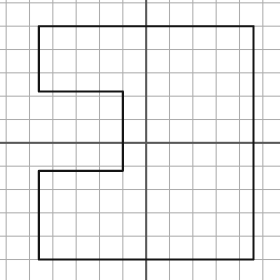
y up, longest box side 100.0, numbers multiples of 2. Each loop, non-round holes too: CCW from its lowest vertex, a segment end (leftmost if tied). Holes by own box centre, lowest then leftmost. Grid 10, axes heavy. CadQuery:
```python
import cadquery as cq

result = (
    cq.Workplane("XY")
    .moveTo(-46.0, -50.0)
    .lineTo(46.0, -50.0)
    .lineTo(46.0, 50.0)
    .lineTo(-46.0, 50.0)
    .lineTo(-46.0, 22.0)
    .lineTo(-10.0, 22.0)
    .lineTo(-10.0, -12.0)
    .lineTo(-46.0, -12.0)
    .close()
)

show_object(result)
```